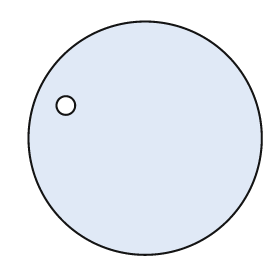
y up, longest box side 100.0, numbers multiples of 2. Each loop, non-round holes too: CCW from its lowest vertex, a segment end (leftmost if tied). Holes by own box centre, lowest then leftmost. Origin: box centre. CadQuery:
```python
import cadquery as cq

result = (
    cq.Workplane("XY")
    .moveTo(0.0, 0.0)
    .circle(50.0)
    .moveTo(-34.0, 14.0)
    .circle(4.0)
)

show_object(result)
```